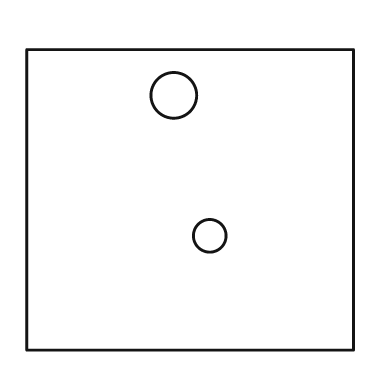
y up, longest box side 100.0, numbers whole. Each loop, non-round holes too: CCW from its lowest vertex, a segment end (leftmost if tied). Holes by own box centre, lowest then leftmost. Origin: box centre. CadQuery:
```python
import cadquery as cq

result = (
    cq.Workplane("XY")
    .moveTo(-50.0, -46.0)
    .lineTo(50.0, -46.0)
    .lineTo(50.0, 46.0)
    .lineTo(-50.0, 46.0)
    .close()
    .moveTo(6.0, -11.0)
    .circle(5.0)
    .moveTo(-5.0, 32.0)
    .circle(7.0)
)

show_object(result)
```